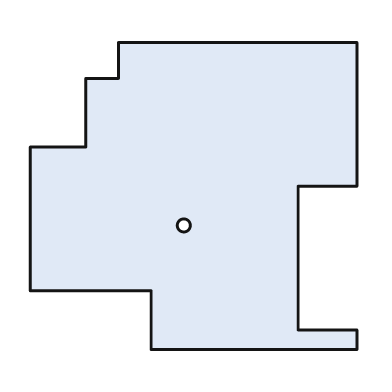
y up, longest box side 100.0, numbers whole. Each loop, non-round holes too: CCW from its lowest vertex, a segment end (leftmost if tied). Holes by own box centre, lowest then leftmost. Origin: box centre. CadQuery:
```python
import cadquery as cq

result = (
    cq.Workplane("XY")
    .moveTo(-13.0, -47.0)
    .lineTo(50.0, -47.0)
    .lineTo(50.0, -41.0)
    .lineTo(32.0, -41.0)
    .lineTo(32.0, 3.0)
    .lineTo(50.0, 3.0)
    .lineTo(50.0, 47.0)
    .lineTo(-23.0, 47.0)
    .lineTo(-23.0, 36.0)
    .lineTo(-33.0, 36.0)
    .lineTo(-33.0, 15.0)
    .lineTo(-50.0, 15.0)
    .lineTo(-50.0, -29.0)
    .lineTo(-13.0, -29.0)
    .close()
    .moveTo(-3.0, -9.0)
    .circle(2.0)
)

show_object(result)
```